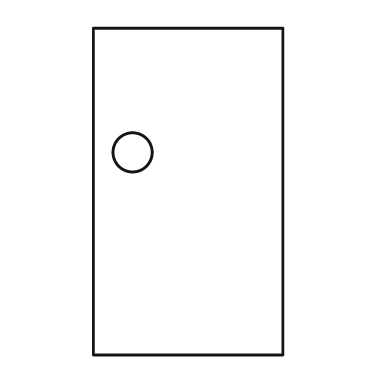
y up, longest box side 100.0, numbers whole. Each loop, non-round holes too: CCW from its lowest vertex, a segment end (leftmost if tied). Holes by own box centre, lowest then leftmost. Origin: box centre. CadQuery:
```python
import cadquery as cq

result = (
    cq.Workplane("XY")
    .moveTo(-29.0, -50.0)
    .lineTo(29.0, -50.0)
    .lineTo(29.0, 50.0)
    .lineTo(-29.0, 50.0)
    .close()
    .moveTo(-17.0, 12.0)
    .circle(6.0)
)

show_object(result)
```